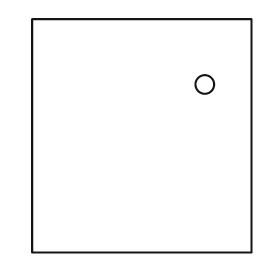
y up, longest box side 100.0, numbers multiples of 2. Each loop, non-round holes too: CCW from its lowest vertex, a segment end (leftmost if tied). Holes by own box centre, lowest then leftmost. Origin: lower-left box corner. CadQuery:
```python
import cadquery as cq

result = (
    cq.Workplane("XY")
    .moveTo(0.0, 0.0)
    .lineTo(94.0, 0.0)
    .lineTo(94.0, 100.0)
    .lineTo(0.0, 100.0)
    .close()
    .moveTo(74.0, 72.0)
    .circle(4.0)
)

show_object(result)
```